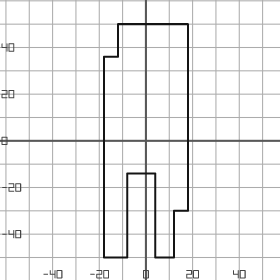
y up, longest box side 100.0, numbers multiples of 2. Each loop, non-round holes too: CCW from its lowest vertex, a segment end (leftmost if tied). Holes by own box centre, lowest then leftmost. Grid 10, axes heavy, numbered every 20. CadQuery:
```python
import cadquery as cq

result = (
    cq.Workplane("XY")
    .moveTo(-18.0, -50.0)
    .lineTo(-8.0, -50.0)
    .lineTo(-8.0, -14.0)
    .lineTo(4.0, -14.0)
    .lineTo(4.0, -50.0)
    .lineTo(12.0, -50.0)
    .lineTo(12.0, -30.0)
    .lineTo(18.0, -30.0)
    .lineTo(18.0, 50.0)
    .lineTo(-12.0, 50.0)
    .lineTo(-12.0, 36.0)
    .lineTo(-18.0, 36.0)
    .close()
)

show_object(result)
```